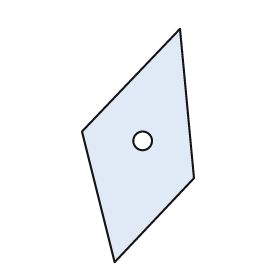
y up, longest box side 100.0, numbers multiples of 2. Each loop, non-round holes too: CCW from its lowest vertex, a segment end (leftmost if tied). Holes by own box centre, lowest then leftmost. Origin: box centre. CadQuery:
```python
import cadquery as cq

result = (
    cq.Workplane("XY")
    .moveTo(-10.0, -50.0)
    .lineTo(24.0, -14.0)
    .lineTo(18.0, 50.0)
    .lineTo(-24.0, 6.0)
    .close()
    .moveTo(2.0, 2.0)
    .circle(4.0)
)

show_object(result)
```